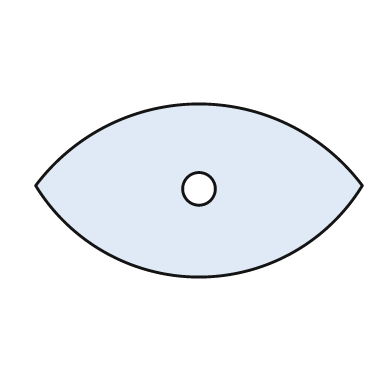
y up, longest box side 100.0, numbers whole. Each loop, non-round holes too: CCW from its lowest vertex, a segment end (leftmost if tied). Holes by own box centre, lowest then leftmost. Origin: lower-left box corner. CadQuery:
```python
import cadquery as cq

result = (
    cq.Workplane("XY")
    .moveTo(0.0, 28.0)
    .threePointArc((50.0, 0.0), (100.0, 28.0))
    .threePointArc((50.0, 53.0), (0.0, 28.0))
    .close()
    .moveTo(50.0, 27.0)
    .circle(5.0)
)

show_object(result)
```